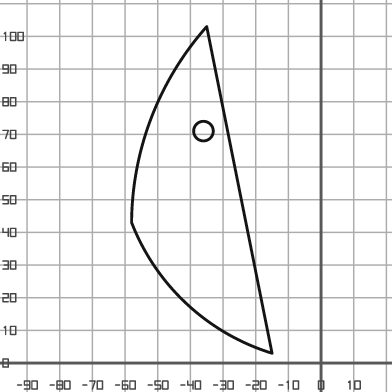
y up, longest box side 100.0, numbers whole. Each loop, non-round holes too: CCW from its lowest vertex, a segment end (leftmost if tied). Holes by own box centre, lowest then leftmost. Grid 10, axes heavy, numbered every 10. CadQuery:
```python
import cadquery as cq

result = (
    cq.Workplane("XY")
    .moveTo(-15.0, 3.0)
    .lineTo(-35.0, 103.0)
    .threePointArc((-52.0, 75.0), (-58.0, 43.0))
    .threePointArc((-41.0, 18.0), (-15.0, 3.0))
    .close()
    .moveTo(-36.0, 71.0)
    .circle(3.0)
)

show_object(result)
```